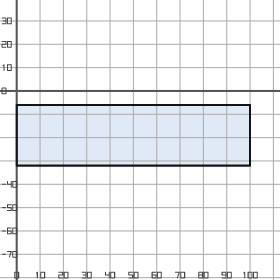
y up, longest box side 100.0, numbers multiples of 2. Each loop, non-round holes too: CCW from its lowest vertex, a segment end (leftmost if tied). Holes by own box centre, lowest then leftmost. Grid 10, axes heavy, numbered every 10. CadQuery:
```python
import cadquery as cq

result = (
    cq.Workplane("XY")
    .moveTo(0.0, -32.0)
    .lineTo(100.0, -32.0)
    .lineTo(100.0, -6.0)
    .lineTo(0.0, -6.0)
    .close()
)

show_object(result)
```